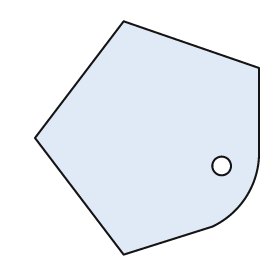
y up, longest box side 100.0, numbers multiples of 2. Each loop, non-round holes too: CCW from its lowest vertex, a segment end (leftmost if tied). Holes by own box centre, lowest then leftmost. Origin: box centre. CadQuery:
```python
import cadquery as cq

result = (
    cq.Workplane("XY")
    .moveTo(-10.0, -50.0)
    .lineTo(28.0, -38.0)
    .threePointArc((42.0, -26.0), (48.0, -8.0))
    .lineTo(48.0, 30.0)
    .lineTo(-10.0, 50.0)
    .lineTo(-48.0, 0.0)
    .close()
    .moveTo(32.0, -12.0)
    .circle(4.0)
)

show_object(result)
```